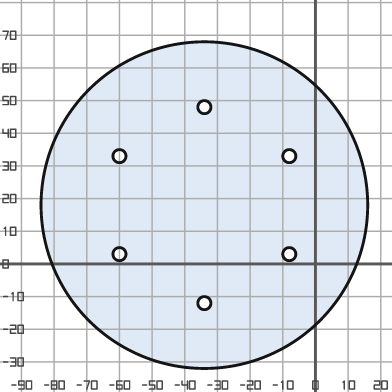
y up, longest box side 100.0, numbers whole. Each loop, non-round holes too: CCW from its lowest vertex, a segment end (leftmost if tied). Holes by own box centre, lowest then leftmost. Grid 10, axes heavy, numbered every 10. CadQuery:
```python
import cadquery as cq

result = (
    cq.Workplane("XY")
    .moveTo(-34.0, 18.0)
    .circle(50.0)
    .moveTo(-34.0, -12.0)
    .circle(2.0)
    .moveTo(-60.0, 3.0)
    .circle(2.0)
    .moveTo(-8.0, 3.0)
    .circle(2.0)
    .moveTo(-60.0, 33.0)
    .circle(2.0)
    .moveTo(-8.0, 33.0)
    .circle(2.0)
    .moveTo(-34.0, 48.0)
    .circle(2.0)
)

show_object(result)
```